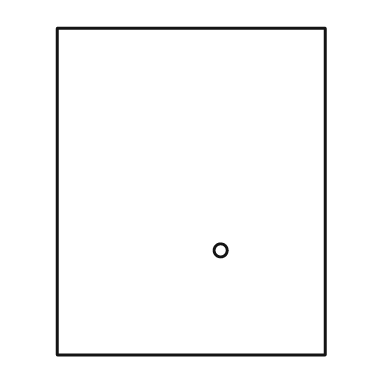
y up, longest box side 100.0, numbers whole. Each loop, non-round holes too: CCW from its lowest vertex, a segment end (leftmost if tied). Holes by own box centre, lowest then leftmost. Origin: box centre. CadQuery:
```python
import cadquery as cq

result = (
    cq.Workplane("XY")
    .moveTo(-41.0, -50.0)
    .lineTo(41.0, -50.0)
    .lineTo(41.0, 50.0)
    .lineTo(-41.0, 50.0)
    .close()
    .moveTo(9.0, -18.0)
    .circle(2.0)
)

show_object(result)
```